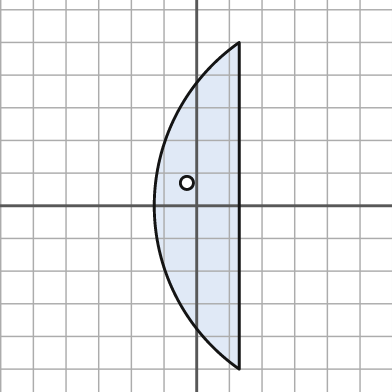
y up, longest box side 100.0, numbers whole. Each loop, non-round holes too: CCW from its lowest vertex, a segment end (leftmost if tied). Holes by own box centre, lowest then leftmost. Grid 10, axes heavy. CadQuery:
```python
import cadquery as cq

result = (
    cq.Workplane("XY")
    .moveTo(13.0, -50.0)
    .lineTo(13.0, 50.0)
    .threePointArc((-13.0, 0.0), (13.0, -50.0))
    .close()
    .moveTo(-3.0, 7.0)
    .circle(2.0)
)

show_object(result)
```